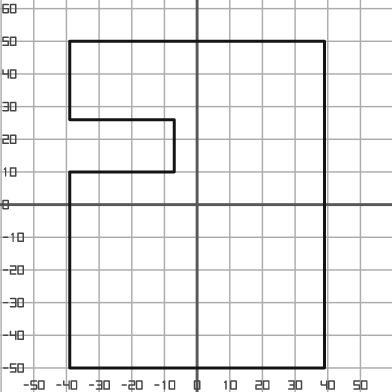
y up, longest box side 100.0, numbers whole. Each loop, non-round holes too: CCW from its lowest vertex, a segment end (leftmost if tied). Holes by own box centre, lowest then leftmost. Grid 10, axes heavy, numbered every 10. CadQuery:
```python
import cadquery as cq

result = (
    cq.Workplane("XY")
    .moveTo(-39.0, -50.0)
    .lineTo(39.0, -50.0)
    .lineTo(39.0, 50.0)
    .lineTo(-39.0, 50.0)
    .lineTo(-39.0, 26.0)
    .lineTo(-7.0, 26.0)
    .lineTo(-7.0, 10.0)
    .lineTo(-39.0, 10.0)
    .close()
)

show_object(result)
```